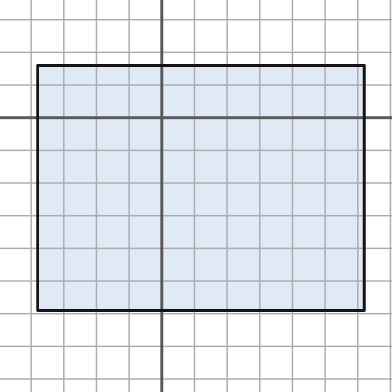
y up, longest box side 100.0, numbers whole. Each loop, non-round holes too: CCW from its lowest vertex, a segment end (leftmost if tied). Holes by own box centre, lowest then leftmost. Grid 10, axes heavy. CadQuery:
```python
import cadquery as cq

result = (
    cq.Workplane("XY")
    .moveTo(-38.0, -59.0)
    .lineTo(62.0, -59.0)
    .lineTo(62.0, 16.0)
    .lineTo(-38.0, 16.0)
    .close()
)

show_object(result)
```